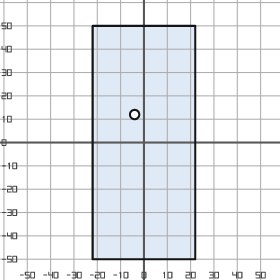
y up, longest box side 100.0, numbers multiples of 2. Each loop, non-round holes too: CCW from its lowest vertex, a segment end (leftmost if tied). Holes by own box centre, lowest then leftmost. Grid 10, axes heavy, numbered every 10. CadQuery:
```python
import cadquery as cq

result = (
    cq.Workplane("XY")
    .moveTo(-22.0, -50.0)
    .lineTo(22.0, -50.0)
    .lineTo(22.0, 50.0)
    .lineTo(-22.0, 50.0)
    .close()
    .moveTo(-4.0, 12.0)
    .circle(2.0)
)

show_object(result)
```